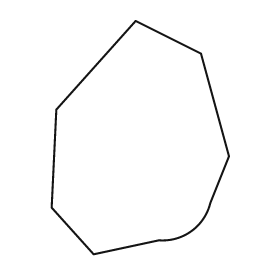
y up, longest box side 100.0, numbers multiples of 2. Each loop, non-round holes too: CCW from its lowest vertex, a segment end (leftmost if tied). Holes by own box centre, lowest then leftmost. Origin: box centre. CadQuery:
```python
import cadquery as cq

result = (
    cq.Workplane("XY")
    .moveTo(-20.0, -50.0)
    .lineTo(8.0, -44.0)
    .threePointArc((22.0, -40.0), (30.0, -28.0))
    .lineTo(38.0, -8.0)
    .lineTo(26.0, 36.0)
    .lineTo(-2.0, 50.0)
    .lineTo(-36.0, 12.0)
    .lineTo(-38.0, -30.0)
    .close()
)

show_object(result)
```